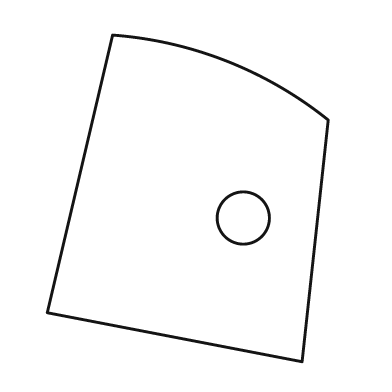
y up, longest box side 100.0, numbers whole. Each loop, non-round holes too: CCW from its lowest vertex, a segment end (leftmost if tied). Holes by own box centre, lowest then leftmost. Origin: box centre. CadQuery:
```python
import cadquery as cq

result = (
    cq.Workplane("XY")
    .moveTo(35.0, -50.0)
    .lineTo(43.0, 24.0)
    .threePointArc((12.0, 42.0), (-23.0, 50.0))
    .lineTo(-43.0, -35.0)
    .close()
    .moveTo(17.0, -6.0)
    .circle(8.0)
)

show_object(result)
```